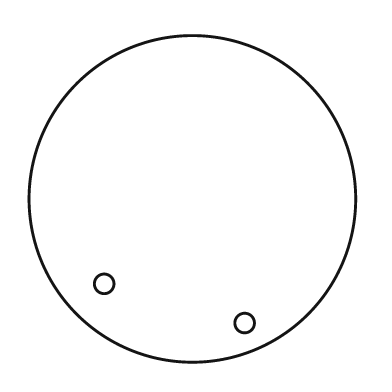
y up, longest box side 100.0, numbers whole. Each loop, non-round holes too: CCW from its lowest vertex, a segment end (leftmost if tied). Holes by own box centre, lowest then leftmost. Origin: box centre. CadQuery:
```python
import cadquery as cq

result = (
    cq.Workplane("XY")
    .moveTo(0.0, 0.0)
    .circle(50.0)
    .moveTo(16.0, -38.0)
    .circle(3.0)
    .moveTo(-27.0, -26.0)
    .circle(3.0)
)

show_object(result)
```